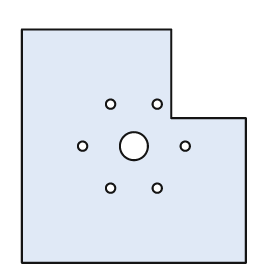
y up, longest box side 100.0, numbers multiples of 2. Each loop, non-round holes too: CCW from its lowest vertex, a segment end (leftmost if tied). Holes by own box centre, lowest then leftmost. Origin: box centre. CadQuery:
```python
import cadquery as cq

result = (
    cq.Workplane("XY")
    .moveTo(-48.0, -50.0)
    .lineTo(48.0, -50.0)
    .lineTo(48.0, 12.0)
    .lineTo(16.0, 12.0)
    .lineTo(16.0, 50.0)
    .lineTo(-48.0, 50.0)
    .close()
    .moveTo(-10.0, -18.0)
    .circle(2.0)
    .moveTo(10.0, -18.0)
    .circle(2.0)
    .moveTo(-22.0, 0.0)
    .circle(2.0)
    .moveTo(0.0, 0.0)
    .circle(6.0)
    .moveTo(22.0, 0.0)
    .circle(2.0)
    .moveTo(-10.0, 18.0)
    .circle(2.0)
    .moveTo(10.0, 18.0)
    .circle(2.0)
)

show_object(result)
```